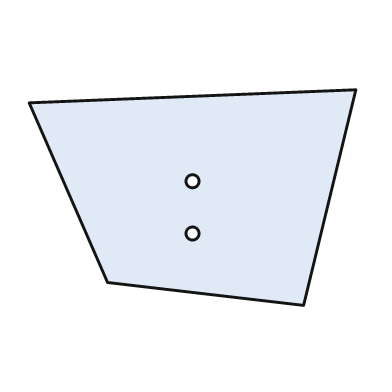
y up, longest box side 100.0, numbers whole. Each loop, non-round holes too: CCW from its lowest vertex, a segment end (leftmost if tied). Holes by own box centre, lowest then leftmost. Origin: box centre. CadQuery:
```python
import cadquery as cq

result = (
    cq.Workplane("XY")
    .moveTo(34.0, -33.0)
    .lineTo(50.0, 33.0)
    .lineTo(-50.0, 29.0)
    .lineTo(-26.0, -26.0)
    .close()
    .moveTo(0.0, -11.0)
    .circle(2.0)
    .moveTo(0.0, 5.0)
    .circle(2.0)
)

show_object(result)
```